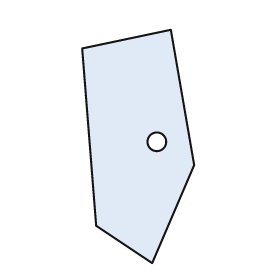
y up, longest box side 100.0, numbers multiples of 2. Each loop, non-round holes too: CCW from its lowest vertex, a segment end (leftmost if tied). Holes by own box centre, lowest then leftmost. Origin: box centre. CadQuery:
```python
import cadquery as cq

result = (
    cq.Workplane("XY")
    .moveTo(6.0, -50.0)
    .lineTo(24.0, -8.0)
    .lineTo(14.0, 50.0)
    .lineTo(-24.0, 42.0)
    .lineTo(-18.0, -34.0)
    .close()
    .moveTo(8.0, 2.0)
    .circle(4.0)
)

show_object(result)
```